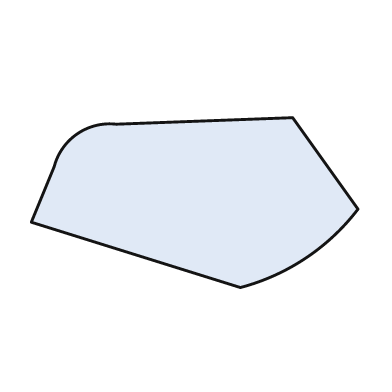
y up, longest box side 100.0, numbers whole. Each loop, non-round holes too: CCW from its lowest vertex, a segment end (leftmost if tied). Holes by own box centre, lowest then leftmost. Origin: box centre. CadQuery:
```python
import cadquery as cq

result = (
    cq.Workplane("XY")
    .moveTo(14.0, -26.0)
    .threePointArc((34.0, -17.0), (50.0, -2.0))
    .lineTo(30.0, 26.0)
    .lineTo(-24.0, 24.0)
    .threePointArc((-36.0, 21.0), (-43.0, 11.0))
    .lineTo(-50.0, -6.0)
    .close()
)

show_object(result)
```